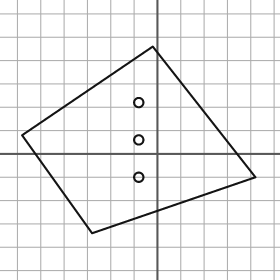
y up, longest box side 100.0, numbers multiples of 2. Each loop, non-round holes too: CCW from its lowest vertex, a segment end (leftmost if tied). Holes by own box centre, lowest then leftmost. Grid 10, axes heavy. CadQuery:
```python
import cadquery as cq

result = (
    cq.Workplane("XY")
    .moveTo(-28.0, -34.0)
    .lineTo(42.0, -10.0)
    .lineTo(-2.0, 46.0)
    .lineTo(-58.0, 8.0)
    .close()
    .moveTo(-8.0, -10.0)
    .circle(2.0)
    .moveTo(-8.0, 6.0)
    .circle(2.0)
    .moveTo(-8.0, 22.0)
    .circle(2.0)
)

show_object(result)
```